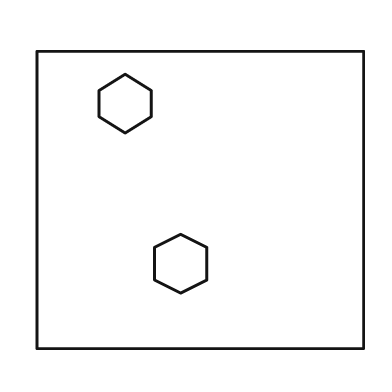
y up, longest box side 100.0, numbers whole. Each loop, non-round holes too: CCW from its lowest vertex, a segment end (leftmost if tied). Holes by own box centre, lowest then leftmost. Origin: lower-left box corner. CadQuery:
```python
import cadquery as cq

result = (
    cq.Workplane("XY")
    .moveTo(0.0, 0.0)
    .lineTo(100.0, 0.0)
    .lineTo(100.0, 91.0)
    .lineTo(0.0, 91.0)
    .close()
    .moveTo(44.0, 17.0)
    .lineTo(52.0, 21.0)
    .lineTo(52.0, 31.0)
    .lineTo(44.0, 35.0)
    .lineTo(36.0, 31.0)
    .lineTo(36.0, 21.0)
    .close()
    .moveTo(27.0, 66.0)
    .lineTo(35.0, 71.0)
    .lineTo(35.0, 79.0)
    .lineTo(27.0, 84.0)
    .lineTo(19.0, 79.0)
    .lineTo(19.0, 71.0)
    .close()
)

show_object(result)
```